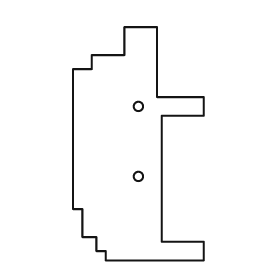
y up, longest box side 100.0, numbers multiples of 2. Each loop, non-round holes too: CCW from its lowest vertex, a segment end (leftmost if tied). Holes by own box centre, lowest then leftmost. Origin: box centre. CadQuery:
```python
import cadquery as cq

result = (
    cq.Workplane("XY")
    .moveTo(-14.0, -50.0)
    .lineTo(28.0, -50.0)
    .lineTo(28.0, -42.0)
    .lineTo(10.0, -42.0)
    .lineTo(10.0, 12.0)
    .lineTo(28.0, 12.0)
    .lineTo(28.0, 20.0)
    .lineTo(8.0, 20.0)
    .lineTo(8.0, 50.0)
    .lineTo(-6.0, 50.0)
    .lineTo(-6.0, 38.0)
    .lineTo(-20.0, 38.0)
    .lineTo(-20.0, 32.0)
    .lineTo(-28.0, 32.0)
    .lineTo(-28.0, -28.0)
    .lineTo(-24.0, -28.0)
    .lineTo(-24.0, -40.0)
    .lineTo(-18.0, -40.0)
    .lineTo(-18.0, -46.0)
    .lineTo(-14.0, -46.0)
    .close()
    .moveTo(0.0, -14.0)
    .circle(2.0)
    .moveTo(0.0, 16.0)
    .circle(2.0)
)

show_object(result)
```